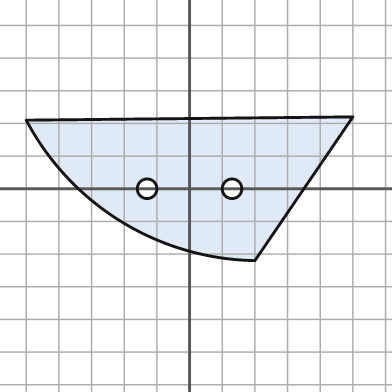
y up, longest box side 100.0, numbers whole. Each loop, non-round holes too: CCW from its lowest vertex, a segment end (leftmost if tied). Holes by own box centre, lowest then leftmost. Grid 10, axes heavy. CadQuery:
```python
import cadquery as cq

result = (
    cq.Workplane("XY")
    .moveTo(20.0, -22.0)
    .lineTo(50.0, 22.0)
    .lineTo(-50.0, 21.0)
    .threePointArc((-21.0, -10.0), (20.0, -22.0))
    .close()
    .moveTo(-13.0, 0.0)
    .circle(3.0)
    .moveTo(13.0, 0.0)
    .circle(3.0)
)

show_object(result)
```